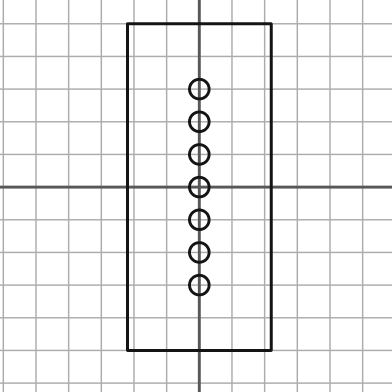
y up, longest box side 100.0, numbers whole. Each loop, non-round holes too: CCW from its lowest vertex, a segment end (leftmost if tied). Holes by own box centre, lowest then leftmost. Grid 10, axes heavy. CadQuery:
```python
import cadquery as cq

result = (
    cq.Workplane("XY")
    .moveTo(-22.0, -50.0)
    .lineTo(22.0, -50.0)
    .lineTo(22.0, 50.0)
    .lineTo(-22.0, 50.0)
    .close()
    .moveTo(0.0, -30.0)
    .circle(3.0)
    .moveTo(0.0, -20.0)
    .circle(3.0)
    .moveTo(0.0, -10.0)
    .circle(3.0)
    .moveTo(0.0, 0.0)
    .circle(3.0)
    .moveTo(0.0, 10.0)
    .circle(3.0)
    .moveTo(0.0, 20.0)
    .circle(3.0)
    .moveTo(0.0, 30.0)
    .circle(3.0)
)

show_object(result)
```